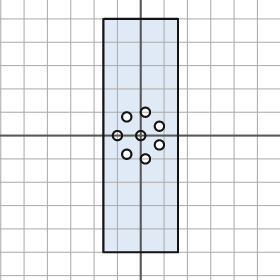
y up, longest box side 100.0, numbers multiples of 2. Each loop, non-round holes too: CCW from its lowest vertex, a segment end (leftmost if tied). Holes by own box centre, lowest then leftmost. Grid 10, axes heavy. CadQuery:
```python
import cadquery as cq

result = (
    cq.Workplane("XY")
    .moveTo(-16.0, -50.0)
    .lineTo(16.0, -50.0)
    .lineTo(16.0, 50.0)
    .lineTo(-16.0, 50.0)
    .close()
    .moveTo(2.0, -10.0)
    .circle(2.0)
    .moveTo(-6.0, -8.0)
    .circle(2.0)
    .moveTo(8.0, -4.0)
    .circle(2.0)
    .moveTo(-10.0, 0.0)
    .circle(2.0)
    .moveTo(0.0, 0.0)
    .circle(2.0)
    .moveTo(8.0, 4.0)
    .circle(2.0)
    .moveTo(-6.0, 8.0)
    .circle(2.0)
    .moveTo(2.0, 10.0)
    .circle(2.0)
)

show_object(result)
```